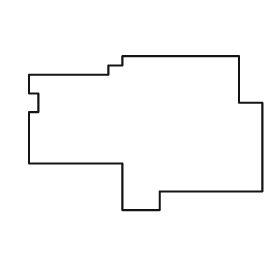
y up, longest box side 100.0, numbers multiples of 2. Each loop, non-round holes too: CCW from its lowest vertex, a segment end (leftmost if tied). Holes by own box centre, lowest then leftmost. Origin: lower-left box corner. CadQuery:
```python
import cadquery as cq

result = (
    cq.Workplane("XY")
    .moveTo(40.0, 0.0)
    .lineTo(56.0, 0.0)
    .lineTo(56.0, 8.0)
    .lineTo(100.0, 8.0)
    .lineTo(100.0, 46.0)
    .lineTo(90.0, 46.0)
    .lineTo(90.0, 66.0)
    .lineTo(40.0, 66.0)
    .lineTo(40.0, 62.0)
    .lineTo(34.0, 62.0)
    .lineTo(34.0, 58.0)
    .lineTo(0.0, 58.0)
    .lineTo(0.0, 50.0)
    .lineTo(4.0, 50.0)
    .lineTo(4.0, 42.0)
    .lineTo(0.0, 42.0)
    .lineTo(0.0, 20.0)
    .lineTo(40.0, 20.0)
    .close()
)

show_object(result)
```